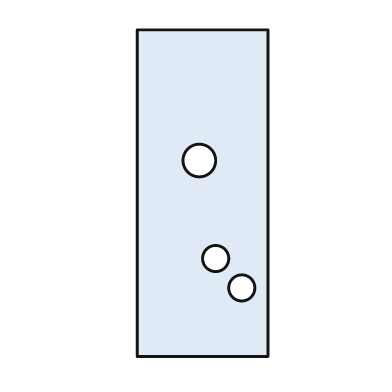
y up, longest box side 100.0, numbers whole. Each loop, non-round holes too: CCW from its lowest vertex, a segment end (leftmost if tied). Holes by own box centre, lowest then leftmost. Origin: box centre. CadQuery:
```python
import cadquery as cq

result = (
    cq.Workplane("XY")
    .moveTo(-20.0, -50.0)
    .lineTo(20.0, -50.0)
    .lineTo(20.0, 50.0)
    .lineTo(-20.0, 50.0)
    .close()
    .moveTo(12.0, -29.0)
    .circle(4.0)
    .moveTo(4.0, -20.0)
    .circle(4.0)
    .moveTo(-1.0, 10.0)
    .circle(5.0)
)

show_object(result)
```